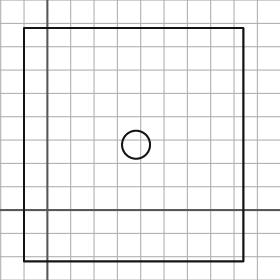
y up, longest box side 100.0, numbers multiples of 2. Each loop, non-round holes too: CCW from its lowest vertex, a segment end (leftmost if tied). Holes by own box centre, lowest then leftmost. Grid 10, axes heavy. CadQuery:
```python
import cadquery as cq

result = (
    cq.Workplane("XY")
    .moveTo(-10.0, -22.0)
    .lineTo(84.0, -22.0)
    .lineTo(84.0, 78.0)
    .lineTo(-10.0, 78.0)
    .close()
    .moveTo(38.0, 28.0)
    .circle(6.0)
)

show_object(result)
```